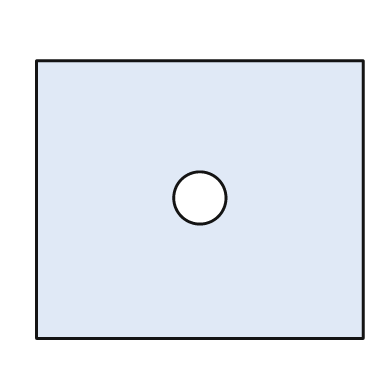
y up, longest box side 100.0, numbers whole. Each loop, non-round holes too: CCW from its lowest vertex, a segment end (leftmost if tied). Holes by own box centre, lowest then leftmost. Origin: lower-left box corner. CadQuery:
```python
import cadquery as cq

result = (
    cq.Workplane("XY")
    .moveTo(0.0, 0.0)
    .lineTo(100.0, 0.0)
    .lineTo(100.0, 85.0)
    .lineTo(0.0, 85.0)
    .close()
    .moveTo(50.0, 43.0)
    .circle(8.0)
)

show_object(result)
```